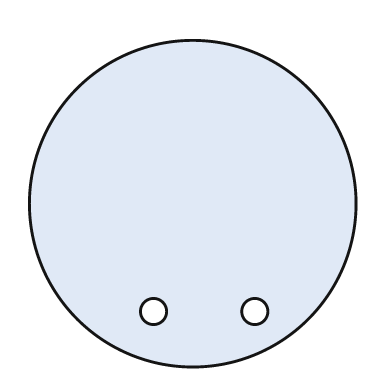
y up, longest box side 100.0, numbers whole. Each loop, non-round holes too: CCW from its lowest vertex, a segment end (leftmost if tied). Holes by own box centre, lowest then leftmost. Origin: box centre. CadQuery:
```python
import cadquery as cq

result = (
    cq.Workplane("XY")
    .moveTo(0.0, 0.0)
    .circle(50.0)
    .moveTo(-12.0, -33.0)
    .circle(4.0)
    .moveTo(19.0, -33.0)
    .circle(4.0)
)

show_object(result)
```